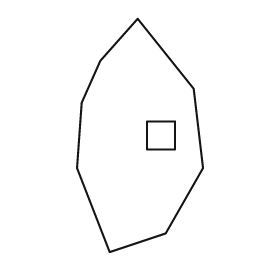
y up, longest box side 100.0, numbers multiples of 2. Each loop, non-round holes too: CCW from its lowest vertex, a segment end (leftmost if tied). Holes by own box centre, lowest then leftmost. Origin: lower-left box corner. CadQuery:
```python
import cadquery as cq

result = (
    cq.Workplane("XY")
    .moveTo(14.0, 0.0)
    .lineTo(38.0, 8.0)
    .lineTo(54.0, 36.0)
    .lineTo(50.0, 70.0)
    .lineTo(26.0, 100.0)
    .lineTo(10.0, 82.0)
    .lineTo(2.0, 64.0)
    .lineTo(0.0, 36.0)
    .close()
    .moveTo(30.0, 44.0)
    .lineTo(42.0, 44.0)
    .lineTo(42.0, 56.0)
    .lineTo(30.0, 56.0)
    .close()
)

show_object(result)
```